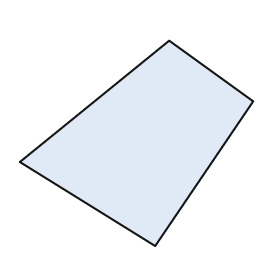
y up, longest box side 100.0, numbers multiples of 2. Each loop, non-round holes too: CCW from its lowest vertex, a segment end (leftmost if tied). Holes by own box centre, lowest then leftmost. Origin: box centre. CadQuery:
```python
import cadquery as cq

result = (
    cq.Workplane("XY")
    .moveTo(8.0, -44.0)
    .lineTo(50.0, 18.0)
    .lineTo(14.0, 44.0)
    .lineTo(-50.0, -8.0)
    .close()
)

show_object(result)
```